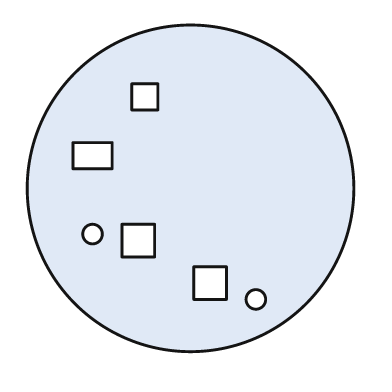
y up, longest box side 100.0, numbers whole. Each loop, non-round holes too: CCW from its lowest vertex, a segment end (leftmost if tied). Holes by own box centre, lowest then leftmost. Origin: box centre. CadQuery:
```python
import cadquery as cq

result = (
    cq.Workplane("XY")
    .moveTo(0.0, 0.0)
    .circle(50.0)
    .moveTo(20.0, -34.0)
    .circle(3.0)
    .moveTo(1.0, -34.0)
    .lineTo(11.0, -34.0)
    .lineTo(11.0, -24.0)
    .lineTo(1.0, -24.0)
    .close()
    .moveTo(-21.0, -21.0)
    .lineTo(-11.0, -21.0)
    .lineTo(-11.0, -11.0)
    .lineTo(-21.0, -11.0)
    .close()
    .moveTo(-30.0, -14.0)
    .circle(3.0)
    .moveTo(-36.0, 6.0)
    .lineTo(-24.0, 6.0)
    .lineTo(-24.0, 14.0)
    .lineTo(-36.0, 14.0)
    .close()
    .moveTo(-18.0, 24.0)
    .lineTo(-10.0, 24.0)
    .lineTo(-10.0, 32.0)
    .lineTo(-18.0, 32.0)
    .close()
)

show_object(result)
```